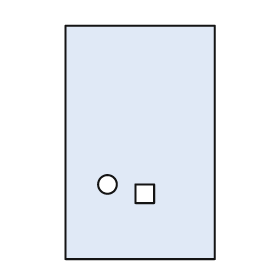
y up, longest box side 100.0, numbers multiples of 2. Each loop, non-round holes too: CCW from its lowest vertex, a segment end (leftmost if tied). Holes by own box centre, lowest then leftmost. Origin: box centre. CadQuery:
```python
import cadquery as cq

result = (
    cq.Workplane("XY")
    .moveTo(-32.0, -50.0)
    .lineTo(32.0, -50.0)
    .lineTo(32.0, 50.0)
    .lineTo(-32.0, 50.0)
    .close()
    .moveTo(-2.0, -26.0)
    .lineTo(6.0, -26.0)
    .lineTo(6.0, -18.0)
    .lineTo(-2.0, -18.0)
    .close()
    .moveTo(-14.0, -18.0)
    .circle(4.0)
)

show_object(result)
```